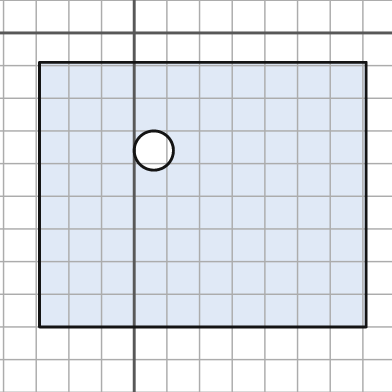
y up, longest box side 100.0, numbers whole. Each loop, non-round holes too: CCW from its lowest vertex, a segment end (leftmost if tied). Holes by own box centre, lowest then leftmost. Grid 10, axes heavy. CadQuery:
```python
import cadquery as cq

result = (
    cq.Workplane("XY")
    .moveTo(-29.0, -90.0)
    .lineTo(71.0, -90.0)
    .lineTo(71.0, -9.0)
    .lineTo(-29.0, -9.0)
    .close()
    .moveTo(6.0, -36.0)
    .circle(6.0)
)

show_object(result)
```